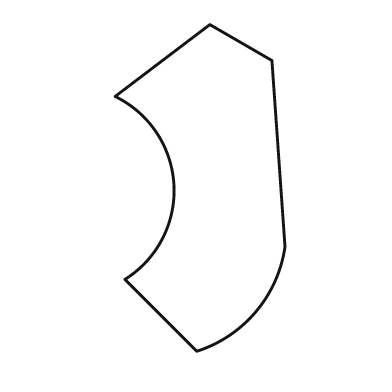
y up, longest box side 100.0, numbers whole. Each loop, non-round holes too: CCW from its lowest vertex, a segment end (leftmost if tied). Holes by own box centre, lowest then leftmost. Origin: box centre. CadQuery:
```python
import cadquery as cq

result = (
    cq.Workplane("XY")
    .moveTo(-1.0, -50.0)
    .threePointArc((17.0, -38.0), (26.0, -18.0))
    .lineTo(22.0, 39.0)
    .lineTo(3.0, 50.0)
    .lineTo(-26.0, 28.0)
    .threePointArc((-8.0, 1.0), (-23.0, -28.0))
    .close()
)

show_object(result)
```